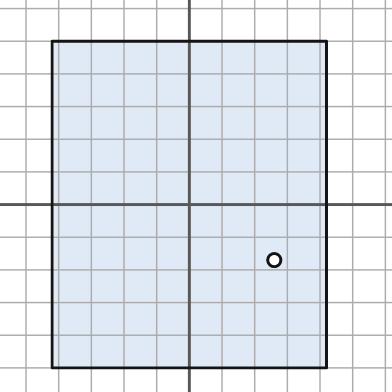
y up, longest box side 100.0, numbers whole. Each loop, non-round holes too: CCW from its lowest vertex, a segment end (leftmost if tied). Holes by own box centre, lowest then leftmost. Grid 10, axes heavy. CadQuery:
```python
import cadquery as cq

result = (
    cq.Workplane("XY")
    .moveTo(-42.0, -50.0)
    .lineTo(42.0, -50.0)
    .lineTo(42.0, 50.0)
    .lineTo(-42.0, 50.0)
    .close()
    .moveTo(26.0, -17.0)
    .circle(2.0)
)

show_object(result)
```